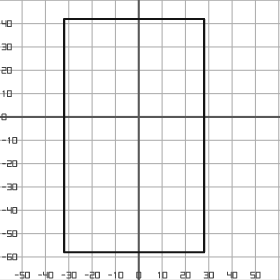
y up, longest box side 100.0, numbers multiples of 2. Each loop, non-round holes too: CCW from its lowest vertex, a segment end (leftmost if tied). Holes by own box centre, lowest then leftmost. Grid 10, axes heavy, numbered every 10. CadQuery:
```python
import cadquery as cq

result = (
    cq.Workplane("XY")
    .moveTo(-32.0, -58.0)
    .lineTo(28.0, -58.0)
    .lineTo(28.0, 42.0)
    .lineTo(-32.0, 42.0)
    .close()
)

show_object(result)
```